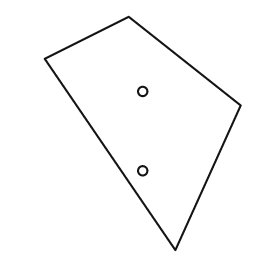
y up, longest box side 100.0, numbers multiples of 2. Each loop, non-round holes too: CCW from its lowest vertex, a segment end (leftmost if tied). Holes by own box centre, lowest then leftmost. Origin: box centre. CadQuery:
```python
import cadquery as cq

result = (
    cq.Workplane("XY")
    .moveTo(14.0, -50.0)
    .lineTo(42.0, 12.0)
    .lineTo(-6.0, 50.0)
    .lineTo(-42.0, 32.0)
    .close()
    .moveTo(0.0, -16.0)
    .circle(2.0)
    .moveTo(0.0, 18.0)
    .circle(2.0)
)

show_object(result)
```